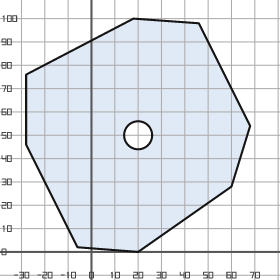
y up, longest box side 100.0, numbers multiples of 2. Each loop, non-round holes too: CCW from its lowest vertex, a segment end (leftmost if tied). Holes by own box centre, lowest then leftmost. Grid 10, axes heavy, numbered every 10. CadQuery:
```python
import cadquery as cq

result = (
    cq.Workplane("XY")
    .moveTo(20.0, 0.0)
    .lineTo(60.0, 28.0)
    .lineTo(68.0, 54.0)
    .lineTo(46.0, 98.0)
    .lineTo(18.0, 100.0)
    .lineTo(-28.0, 76.0)
    .lineTo(-28.0, 46.0)
    .lineTo(-6.0, 2.0)
    .close()
    .moveTo(20.0, 50.0)
    .circle(6.0)
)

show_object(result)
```